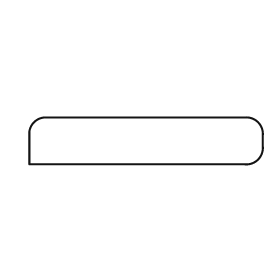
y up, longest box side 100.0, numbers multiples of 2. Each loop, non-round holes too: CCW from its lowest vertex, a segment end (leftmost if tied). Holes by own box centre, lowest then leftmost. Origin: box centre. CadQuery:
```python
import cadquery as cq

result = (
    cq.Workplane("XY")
    .moveTo(-50.0, -10.0)
    .lineTo(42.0, -10.0)
    .threePointArc((48.0, -8.0), (50.0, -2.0))
    .lineTo(50.0, 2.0)
    .threePointArc((48.0, 8.0), (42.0, 10.0))
    .lineTo(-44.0, 10.0)
    .threePointArc((-48.0, 8.0), (-50.0, 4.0))
    .close()
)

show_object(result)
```